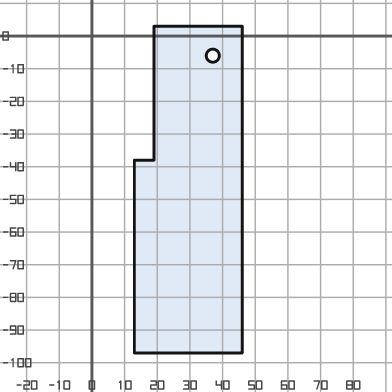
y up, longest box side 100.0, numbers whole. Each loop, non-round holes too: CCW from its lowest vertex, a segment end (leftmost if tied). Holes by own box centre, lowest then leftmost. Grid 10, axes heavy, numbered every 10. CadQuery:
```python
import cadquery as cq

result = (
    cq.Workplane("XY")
    .moveTo(13.0, -97.0)
    .lineTo(46.0, -97.0)
    .lineTo(46.0, 3.0)
    .lineTo(19.0, 3.0)
    .lineTo(19.0, -38.0)
    .lineTo(13.0, -38.0)
    .close()
    .moveTo(37.0, -6.0)
    .circle(2.0)
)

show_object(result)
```